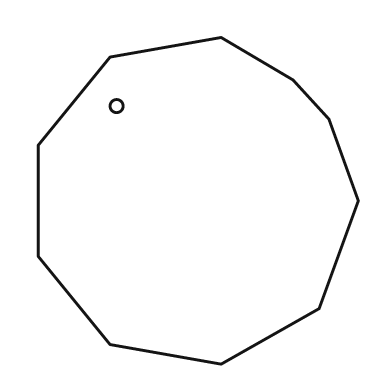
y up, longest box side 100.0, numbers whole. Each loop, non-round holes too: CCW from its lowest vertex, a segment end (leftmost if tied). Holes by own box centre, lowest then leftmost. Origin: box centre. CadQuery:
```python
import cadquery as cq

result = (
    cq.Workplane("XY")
    .moveTo(7.0, -50.0)
    .lineTo(37.0, -33.0)
    .lineTo(49.0, 0.0)
    .lineTo(40.0, 25.0)
    .lineTo(29.0, 37.0)
    .lineTo(7.0, 50.0)
    .lineTo(-27.0, 44.0)
    .lineTo(-49.0, 17.0)
    .lineTo(-49.0, -17.0)
    .lineTo(-27.0, -44.0)
    .close()
    .moveTo(-25.0, 29.0)
    .circle(2.0)
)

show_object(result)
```